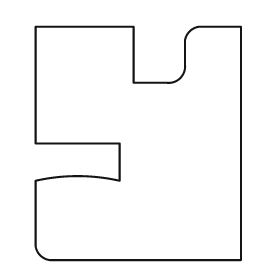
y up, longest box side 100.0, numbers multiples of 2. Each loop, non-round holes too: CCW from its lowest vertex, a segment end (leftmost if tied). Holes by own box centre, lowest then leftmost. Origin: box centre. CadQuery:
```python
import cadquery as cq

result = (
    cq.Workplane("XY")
    .moveTo(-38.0, -50.0)
    .lineTo(44.0, -50.0)
    .lineTo(44.0, 50.0)
    .lineTo(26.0, 50.0)
    .threePointArc((22.0, 48.0), (20.0, 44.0))
    .lineTo(20.0, 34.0)
    .threePointArc((18.0, 28.0), (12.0, 26.0))
    .lineTo(-2.0, 26.0)
    .lineTo(-2.0, 50.0)
    .lineTo(-44.0, 50.0)
    .lineTo(-44.0, 0.0)
    .lineTo(-8.0, 0.0)
    .lineTo(-8.0, -16.0)
    .threePointArc((-26.0, -14.0), (-44.0, -16.0))
    .lineTo(-44.0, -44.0)
    .threePointArc((-42.0, -48.0), (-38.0, -50.0))
    .close()
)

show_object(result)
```